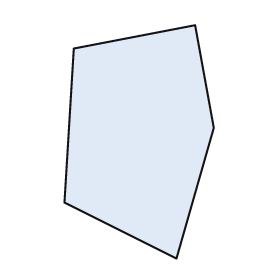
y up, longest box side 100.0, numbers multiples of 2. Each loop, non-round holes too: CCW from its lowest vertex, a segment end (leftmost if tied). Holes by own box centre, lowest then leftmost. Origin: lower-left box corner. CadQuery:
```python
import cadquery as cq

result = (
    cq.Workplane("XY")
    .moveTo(48.0, 0.0)
    .lineTo(64.0, 56.0)
    .lineTo(56.0, 100.0)
    .lineTo(4.0, 90.0)
    .lineTo(0.0, 24.0)
    .close()
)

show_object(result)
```